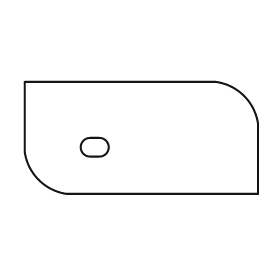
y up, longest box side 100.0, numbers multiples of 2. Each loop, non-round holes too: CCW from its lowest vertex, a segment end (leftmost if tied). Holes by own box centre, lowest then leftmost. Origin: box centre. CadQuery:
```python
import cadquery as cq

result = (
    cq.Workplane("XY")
    .moveTo(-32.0, -24.0)
    .lineTo(50.0, -24.0)
    .lineTo(50.0, 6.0)
    .threePointArc((44.0, 18.0), (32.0, 24.0))
    .lineTo(-50.0, 24.0)
    .lineTo(-50.0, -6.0)
    .threePointArc((-44.0, -18.0), (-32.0, -24.0))
    .close()
    .moveTo(-22.0, -8.0)
    .lineTo(-18.0, -8.0)
    .threePointArc((-14.0, -4.0), (-18.0, 0.0))
    .lineTo(-22.0, 0.0)
    .threePointArc((-26.0, -4.0), (-22.0, -8.0))
    .close()
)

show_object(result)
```